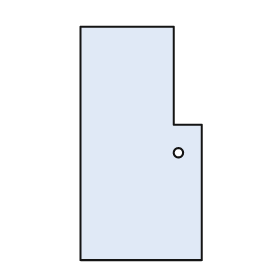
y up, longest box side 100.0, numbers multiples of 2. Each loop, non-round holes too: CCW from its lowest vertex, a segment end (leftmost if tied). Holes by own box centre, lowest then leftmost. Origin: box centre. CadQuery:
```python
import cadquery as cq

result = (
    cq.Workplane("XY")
    .moveTo(-26.0, -50.0)
    .lineTo(26.0, -50.0)
    .lineTo(26.0, 8.0)
    .lineTo(14.0, 8.0)
    .lineTo(14.0, 50.0)
    .lineTo(-26.0, 50.0)
    .close()
    .moveTo(16.0, -4.0)
    .circle(2.0)
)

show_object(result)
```